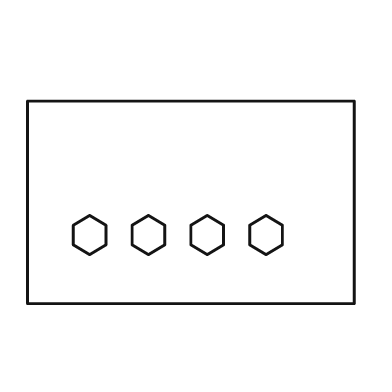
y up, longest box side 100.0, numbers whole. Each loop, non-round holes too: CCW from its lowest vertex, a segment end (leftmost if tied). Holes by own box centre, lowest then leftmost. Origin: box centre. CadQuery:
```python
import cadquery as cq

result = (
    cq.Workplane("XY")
    .moveTo(-50.0, -31.0)
    .lineTo(50.0, -31.0)
    .lineTo(50.0, 31.0)
    .lineTo(-50.0, 31.0)
    .close()
    .moveTo(-31.0, -16.0)
    .lineTo(-26.0, -13.0)
    .lineTo(-26.0, -7.0)
    .lineTo(-31.0, -4.0)
    .lineTo(-36.0, -7.0)
    .lineTo(-36.0, -13.0)
    .close()
    .moveTo(-13.0, -16.0)
    .lineTo(-8.0, -13.0)
    .lineTo(-8.0, -7.0)
    .lineTo(-13.0, -4.0)
    .lineTo(-18.0, -7.0)
    .lineTo(-18.0, -13.0)
    .close()
    .moveTo(5.0, -16.0)
    .lineTo(10.0, -13.0)
    .lineTo(10.0, -7.0)
    .lineTo(5.0, -4.0)
    .lineTo(0.0, -7.0)
    .lineTo(0.0, -13.0)
    .close()
    .moveTo(23.0, -16.0)
    .lineTo(28.0, -13.0)
    .lineTo(28.0, -7.0)
    .lineTo(23.0, -4.0)
    .lineTo(18.0, -7.0)
    .lineTo(18.0, -13.0)
    .close()
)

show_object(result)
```